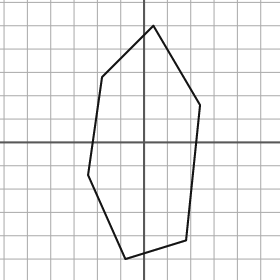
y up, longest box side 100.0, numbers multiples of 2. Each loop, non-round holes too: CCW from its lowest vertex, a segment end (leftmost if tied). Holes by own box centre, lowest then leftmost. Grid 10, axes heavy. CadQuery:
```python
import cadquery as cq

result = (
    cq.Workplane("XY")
    .moveTo(-8.0, -50.0)
    .lineTo(18.0, -42.0)
    .lineTo(24.0, 16.0)
    .lineTo(4.0, 50.0)
    .lineTo(-18.0, 28.0)
    .lineTo(-24.0, -14.0)
    .close()
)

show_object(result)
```